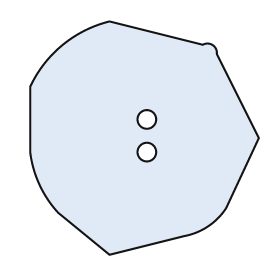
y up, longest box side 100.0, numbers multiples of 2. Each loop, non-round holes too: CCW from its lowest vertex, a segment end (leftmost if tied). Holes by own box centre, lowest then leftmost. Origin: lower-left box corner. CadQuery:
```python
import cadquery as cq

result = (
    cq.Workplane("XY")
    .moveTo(34.0, 0.0)
    .lineTo(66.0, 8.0)
    .threePointArc((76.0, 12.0), (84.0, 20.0))
    .lineTo(98.0, 50.0)
    .lineTo(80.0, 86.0)
    .threePointArc((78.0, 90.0), (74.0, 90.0))
    .lineTo(34.0, 100.0)
    .threePointArc((14.0, 90.0), (0.0, 72.0))
    .lineTo(0.0, 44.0)
    .threePointArc((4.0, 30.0), (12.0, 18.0))
    .close()
    .moveTo(50.0, 44.0)
    .circle(4.0)
    .moveTo(50.0, 58.0)
    .circle(4.0)
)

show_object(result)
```